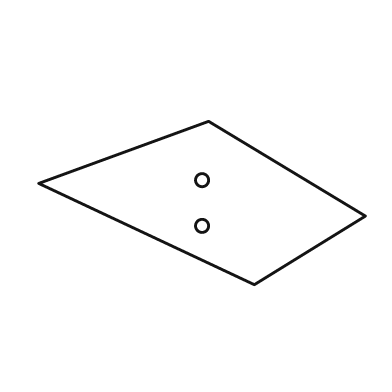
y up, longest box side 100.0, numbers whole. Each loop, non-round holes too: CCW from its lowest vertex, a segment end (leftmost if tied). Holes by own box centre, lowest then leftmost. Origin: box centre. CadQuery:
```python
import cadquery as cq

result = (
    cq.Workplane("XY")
    .moveTo(16.0, -25.0)
    .lineTo(50.0, -4.0)
    .lineTo(2.0, 25.0)
    .lineTo(-50.0, 6.0)
    .close()
    .moveTo(0.0, -7.0)
    .circle(2.0)
    .moveTo(0.0, 7.0)
    .circle(2.0)
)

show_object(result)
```